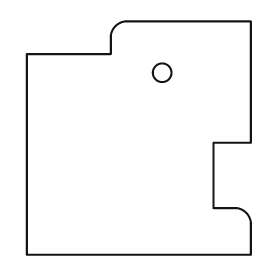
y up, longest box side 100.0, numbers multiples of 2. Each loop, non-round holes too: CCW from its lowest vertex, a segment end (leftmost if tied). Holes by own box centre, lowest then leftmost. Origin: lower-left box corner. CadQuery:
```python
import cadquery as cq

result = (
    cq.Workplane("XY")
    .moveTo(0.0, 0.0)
    .lineTo(96.0, 0.0)
    .lineTo(96.0, 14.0)
    .threePointArc((94.0, 18.0), (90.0, 20.0))
    .lineTo(80.0, 20.0)
    .lineTo(80.0, 48.0)
    .lineTo(96.0, 48.0)
    .lineTo(96.0, 100.0)
    .lineTo(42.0, 100.0)
    .threePointArc((38.0, 98.0), (36.0, 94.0))
    .lineTo(36.0, 86.0)
    .lineTo(0.0, 86.0)
    .close()
    .moveTo(58.0, 78.0)
    .circle(4.0)
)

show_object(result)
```